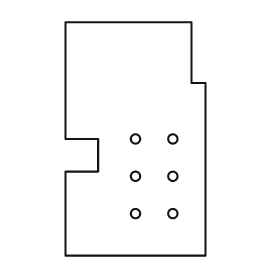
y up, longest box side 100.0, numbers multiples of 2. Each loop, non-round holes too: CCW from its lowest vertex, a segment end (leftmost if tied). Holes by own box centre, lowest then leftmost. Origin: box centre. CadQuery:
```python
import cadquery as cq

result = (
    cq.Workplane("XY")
    .moveTo(-30.0, -50.0)
    .lineTo(30.0, -50.0)
    .lineTo(30.0, 24.0)
    .lineTo(24.0, 24.0)
    .lineTo(24.0, 50.0)
    .lineTo(-30.0, 50.0)
    .lineTo(-30.0, 0.0)
    .lineTo(-16.0, 0.0)
    .lineTo(-16.0, -14.0)
    .lineTo(-30.0, -14.0)
    .close()
    .moveTo(0.0, -32.0)
    .circle(2.0)
    .moveTo(16.0, -32.0)
    .circle(2.0)
    .moveTo(0.0, -16.0)
    .circle(2.0)
    .moveTo(16.0, -16.0)
    .circle(2.0)
    .moveTo(0.0, 0.0)
    .circle(2.0)
    .moveTo(16.0, 0.0)
    .circle(2.0)
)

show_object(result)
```